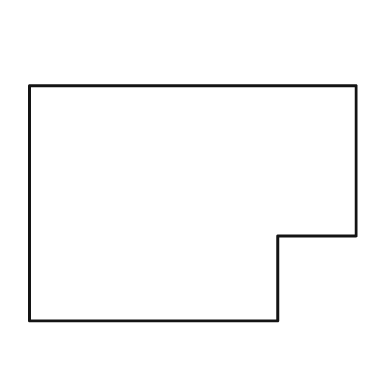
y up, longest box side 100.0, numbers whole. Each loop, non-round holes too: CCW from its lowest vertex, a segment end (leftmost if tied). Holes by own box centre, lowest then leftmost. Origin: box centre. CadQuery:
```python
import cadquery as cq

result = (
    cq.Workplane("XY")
    .moveTo(-50.0, -36.0)
    .lineTo(26.0, -36.0)
    .lineTo(26.0, -10.0)
    .lineTo(50.0, -10.0)
    .lineTo(50.0, 36.0)
    .lineTo(-50.0, 36.0)
    .close()
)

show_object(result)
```